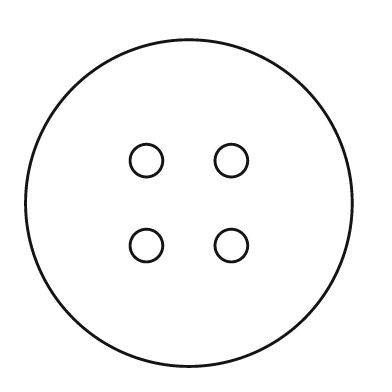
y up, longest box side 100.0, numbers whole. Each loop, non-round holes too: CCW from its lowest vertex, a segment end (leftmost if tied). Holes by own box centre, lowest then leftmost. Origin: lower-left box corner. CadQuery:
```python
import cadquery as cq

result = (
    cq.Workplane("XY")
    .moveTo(50.0, 50.0)
    .circle(50.0)
    .moveTo(37.0, 37.0)
    .circle(5.0)
    .moveTo(63.0, 37.0)
    .circle(5.0)
    .moveTo(37.0, 63.0)
    .circle(5.0)
    .moveTo(63.0, 63.0)
    .circle(5.0)
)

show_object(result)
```